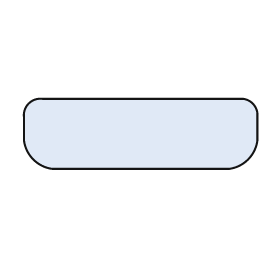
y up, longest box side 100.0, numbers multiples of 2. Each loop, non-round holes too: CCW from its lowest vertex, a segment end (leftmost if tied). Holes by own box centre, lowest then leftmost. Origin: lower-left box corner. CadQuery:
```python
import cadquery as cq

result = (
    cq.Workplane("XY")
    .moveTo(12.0, 0.0)
    .lineTo(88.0, 0.0)
    .threePointArc((96.0, 4.0), (100.0, 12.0))
    .lineTo(100.0, 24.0)
    .threePointArc((98.0, 28.0), (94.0, 30.0))
    .lineTo(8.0, 30.0)
    .threePointArc((2.0, 28.0), (0.0, 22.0))
    .lineTo(0.0, 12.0)
    .threePointArc((4.0, 4.0), (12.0, 0.0))
    .close()
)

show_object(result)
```